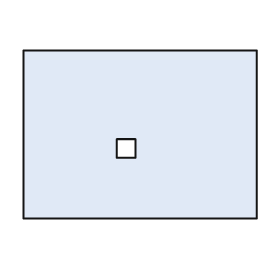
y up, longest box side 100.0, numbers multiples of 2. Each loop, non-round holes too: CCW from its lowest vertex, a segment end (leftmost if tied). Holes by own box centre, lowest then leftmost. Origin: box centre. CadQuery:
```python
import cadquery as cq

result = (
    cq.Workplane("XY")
    .moveTo(-50.0, -36.0)
    .lineTo(50.0, -36.0)
    .lineTo(50.0, 36.0)
    .lineTo(-50.0, 36.0)
    .close()
    .moveTo(-10.0, -10.0)
    .lineTo(-2.0, -10.0)
    .lineTo(-2.0, -2.0)
    .lineTo(-10.0, -2.0)
    .close()
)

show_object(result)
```